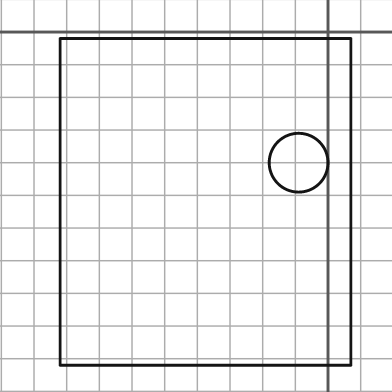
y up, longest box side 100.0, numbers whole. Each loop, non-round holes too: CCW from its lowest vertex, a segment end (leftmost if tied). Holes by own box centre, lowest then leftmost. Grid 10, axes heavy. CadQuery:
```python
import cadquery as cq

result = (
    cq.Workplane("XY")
    .moveTo(-82.0, -102.0)
    .lineTo(7.0, -102.0)
    .lineTo(7.0, -2.0)
    .lineTo(-82.0, -2.0)
    .close()
    .moveTo(-9.0, -40.0)
    .circle(9.0)
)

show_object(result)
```